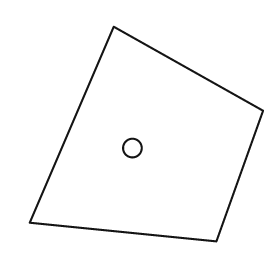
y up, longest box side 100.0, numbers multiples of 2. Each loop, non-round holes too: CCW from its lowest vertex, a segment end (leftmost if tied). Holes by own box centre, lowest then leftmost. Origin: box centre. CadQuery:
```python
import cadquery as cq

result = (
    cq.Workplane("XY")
    .moveTo(30.0, -46.0)
    .lineTo(50.0, 10.0)
    .lineTo(-14.0, 46.0)
    .lineTo(-50.0, -38.0)
    .close()
    .moveTo(-6.0, -6.0)
    .circle(4.0)
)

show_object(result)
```